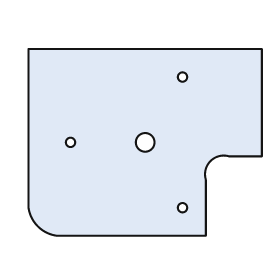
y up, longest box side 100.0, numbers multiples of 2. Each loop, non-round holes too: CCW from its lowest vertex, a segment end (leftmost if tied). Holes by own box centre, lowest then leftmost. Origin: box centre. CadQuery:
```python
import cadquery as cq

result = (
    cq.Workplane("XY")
    .moveTo(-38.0, -40.0)
    .lineTo(26.0, -40.0)
    .lineTo(26.0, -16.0)
    .threePointArc((28.0, -8.0), (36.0, -6.0))
    .lineTo(50.0, -6.0)
    .lineTo(50.0, 40.0)
    .lineTo(-50.0, 40.0)
    .lineTo(-50.0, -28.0)
    .threePointArc((-46.0, -36.0), (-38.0, -40.0))
    .close()
    .moveTo(16.0, -28.0)
    .circle(2.0)
    .moveTo(-32.0, 0.0)
    .circle(2.0)
    .moveTo(0.0, 0.0)
    .circle(4.0)
    .moveTo(16.0, 28.0)
    .circle(2.0)
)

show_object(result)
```